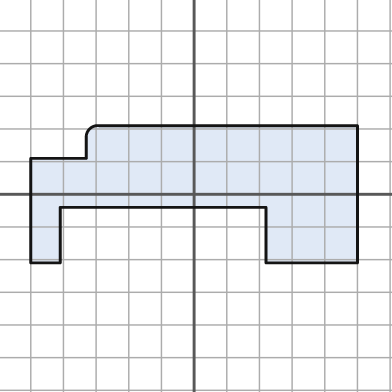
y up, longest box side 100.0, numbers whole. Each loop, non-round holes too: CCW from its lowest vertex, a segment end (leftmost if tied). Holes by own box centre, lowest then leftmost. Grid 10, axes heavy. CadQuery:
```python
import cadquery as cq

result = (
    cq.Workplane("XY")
    .moveTo(-50.0, -21.0)
    .lineTo(-41.0, -21.0)
    .lineTo(-41.0, -4.0)
    .lineTo(22.0, -4.0)
    .lineTo(22.0, -21.0)
    .lineTo(50.0, -21.0)
    .lineTo(50.0, 21.0)
    .lineTo(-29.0, 21.0)
    .threePointArc((-32.0, 20.0), (-33.0, 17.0))
    .lineTo(-33.0, 11.0)
    .lineTo(-50.0, 11.0)
    .close()
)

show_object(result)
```